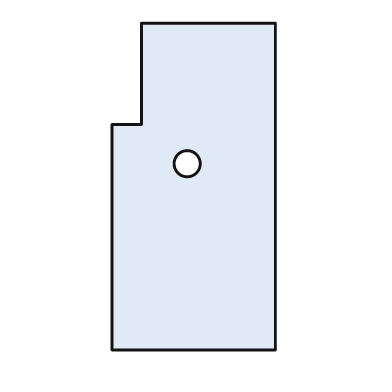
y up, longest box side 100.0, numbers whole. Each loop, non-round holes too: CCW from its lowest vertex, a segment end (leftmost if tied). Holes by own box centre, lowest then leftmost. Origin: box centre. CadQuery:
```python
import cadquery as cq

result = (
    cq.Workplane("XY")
    .moveTo(-25.0, -50.0)
    .lineTo(25.0, -50.0)
    .lineTo(25.0, 50.0)
    .lineTo(-16.0, 50.0)
    .lineTo(-16.0, 19.0)
    .lineTo(-25.0, 19.0)
    .close()
    .moveTo(-2.0, 7.0)
    .circle(4.0)
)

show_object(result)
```